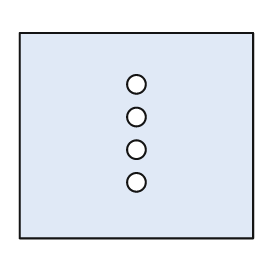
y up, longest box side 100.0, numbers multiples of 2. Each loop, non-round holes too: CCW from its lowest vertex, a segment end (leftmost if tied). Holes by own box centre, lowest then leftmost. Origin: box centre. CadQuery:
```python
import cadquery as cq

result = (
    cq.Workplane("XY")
    .moveTo(-50.0, -44.0)
    .lineTo(50.0, -44.0)
    .lineTo(50.0, 44.0)
    .lineTo(-50.0, 44.0)
    .close()
    .moveTo(0.0, -20.0)
    .circle(4.0)
    .moveTo(0.0, -6.0)
    .circle(4.0)
    .moveTo(0.0, 8.0)
    .circle(4.0)
    .moveTo(0.0, 22.0)
    .circle(4.0)
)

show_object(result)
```